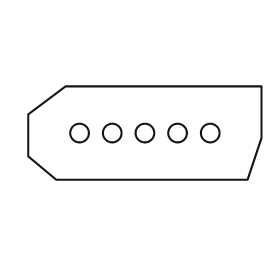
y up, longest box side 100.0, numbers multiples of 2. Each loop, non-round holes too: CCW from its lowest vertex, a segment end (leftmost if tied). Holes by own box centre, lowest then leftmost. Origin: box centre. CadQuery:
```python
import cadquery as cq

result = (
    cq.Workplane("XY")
    .moveTo(-38.0, -20.0)
    .lineTo(44.0, -20.0)
    .lineTo(50.0, -2.0)
    .lineTo(50.0, 20.0)
    .lineTo(-34.0, 20.0)
    .lineTo(-50.0, 8.0)
    .lineTo(-50.0, -10.0)
    .close()
    .moveTo(-28.0, 0.0)
    .circle(4.0)
    .moveTo(-14.0, 0.0)
    .circle(4.0)
    .moveTo(0.0, 0.0)
    .circle(4.0)
    .moveTo(14.0, 0.0)
    .circle(4.0)
    .moveTo(28.0, 0.0)
    .circle(4.0)
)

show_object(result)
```